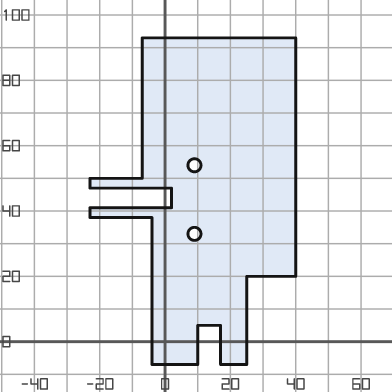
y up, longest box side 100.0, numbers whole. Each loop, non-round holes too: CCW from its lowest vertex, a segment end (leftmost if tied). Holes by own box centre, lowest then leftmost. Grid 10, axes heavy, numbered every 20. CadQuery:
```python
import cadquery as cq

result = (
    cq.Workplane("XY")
    .moveTo(-4.0, -7.0)
    .lineTo(10.0, -7.0)
    .lineTo(10.0, 5.0)
    .lineTo(17.0, 5.0)
    .lineTo(17.0, -7.0)
    .lineTo(25.0, -7.0)
    .lineTo(25.0, 20.0)
    .lineTo(40.0, 20.0)
    .lineTo(40.0, 93.0)
    .lineTo(-7.0, 93.0)
    .lineTo(-7.0, 50.0)
    .lineTo(-23.0, 50.0)
    .lineTo(-23.0, 47.0)
    .lineTo(2.0, 47.0)
    .lineTo(2.0, 41.0)
    .lineTo(-23.0, 41.0)
    .lineTo(-23.0, 38.0)
    .lineTo(-4.0, 38.0)
    .close()
    .moveTo(9.0, 33.0)
    .circle(2.0)
    .moveTo(9.0, 54.0)
    .circle(2.0)
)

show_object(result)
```